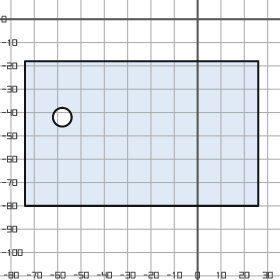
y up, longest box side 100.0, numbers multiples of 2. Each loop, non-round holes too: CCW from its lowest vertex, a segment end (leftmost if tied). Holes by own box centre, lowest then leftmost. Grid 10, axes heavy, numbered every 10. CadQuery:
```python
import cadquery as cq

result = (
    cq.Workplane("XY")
    .moveTo(-74.0, -80.0)
    .lineTo(26.0, -80.0)
    .lineTo(26.0, -18.0)
    .lineTo(-74.0, -18.0)
    .close()
    .moveTo(-58.0, -42.0)
    .circle(4.0)
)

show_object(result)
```